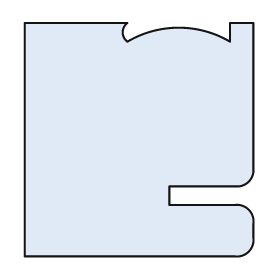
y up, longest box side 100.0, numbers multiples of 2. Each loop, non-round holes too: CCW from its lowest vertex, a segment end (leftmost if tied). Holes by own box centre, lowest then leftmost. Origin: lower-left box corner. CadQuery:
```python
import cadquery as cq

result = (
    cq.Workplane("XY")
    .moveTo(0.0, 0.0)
    .lineTo(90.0, 0.0)
    .threePointArc((96.0, 2.0), (98.0, 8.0))
    .lineTo(98.0, 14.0)
    .threePointArc((96.0, 20.0), (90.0, 22.0))
    .lineTo(62.0, 22.0)
    .lineTo(62.0, 30.0)
    .lineTo(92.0, 30.0)
    .threePointArc((96.0, 32.0), (98.0, 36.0))
    .lineTo(98.0, 100.0)
    .lineTo(88.0, 100.0)
    .lineTo(88.0, 92.0)
    .threePointArc((66.0, 98.0), (44.0, 92.0))
    .threePointArc((42.0, 96.0), (44.0, 100.0))
    .lineTo(0.0, 100.0)
    .close()
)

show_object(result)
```